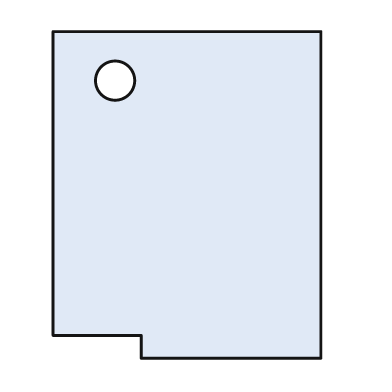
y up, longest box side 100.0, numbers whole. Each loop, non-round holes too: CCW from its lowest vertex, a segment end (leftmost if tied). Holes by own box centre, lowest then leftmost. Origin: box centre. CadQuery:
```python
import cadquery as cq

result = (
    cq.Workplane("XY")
    .moveTo(-14.0, -50.0)
    .lineTo(41.0, -50.0)
    .lineTo(41.0, 50.0)
    .lineTo(-41.0, 50.0)
    .lineTo(-41.0, -43.0)
    .lineTo(-14.0, -43.0)
    .close()
    .moveTo(-22.0, 35.0)
    .circle(6.0)
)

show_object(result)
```